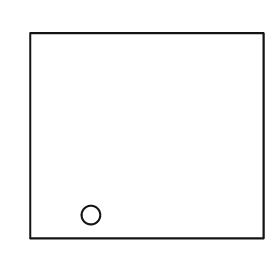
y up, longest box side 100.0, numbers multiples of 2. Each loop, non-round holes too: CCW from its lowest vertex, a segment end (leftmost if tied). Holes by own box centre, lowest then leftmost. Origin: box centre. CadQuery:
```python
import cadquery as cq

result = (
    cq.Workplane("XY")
    .moveTo(-50.0, -44.0)
    .lineTo(50.0, -44.0)
    .lineTo(50.0, 44.0)
    .lineTo(-50.0, 44.0)
    .close()
    .moveTo(-24.0, -34.0)
    .circle(4.0)
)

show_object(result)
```